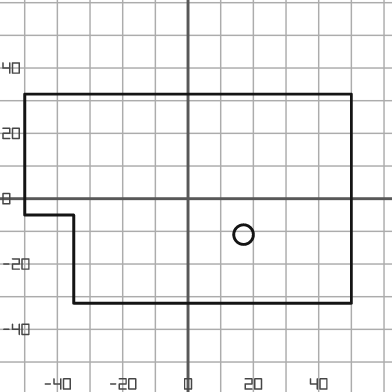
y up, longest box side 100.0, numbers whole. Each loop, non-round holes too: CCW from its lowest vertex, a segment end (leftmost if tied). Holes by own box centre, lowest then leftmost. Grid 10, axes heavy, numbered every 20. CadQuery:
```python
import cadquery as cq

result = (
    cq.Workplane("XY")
    .moveTo(-35.0, -32.0)
    .lineTo(50.0, -32.0)
    .lineTo(50.0, 32.0)
    .lineTo(-50.0, 32.0)
    .lineTo(-50.0, -5.0)
    .lineTo(-35.0, -5.0)
    .close()
    .moveTo(17.0, -11.0)
    .circle(3.0)
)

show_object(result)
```